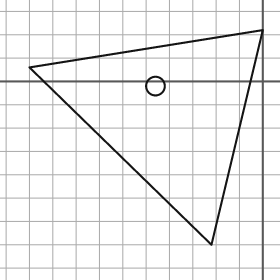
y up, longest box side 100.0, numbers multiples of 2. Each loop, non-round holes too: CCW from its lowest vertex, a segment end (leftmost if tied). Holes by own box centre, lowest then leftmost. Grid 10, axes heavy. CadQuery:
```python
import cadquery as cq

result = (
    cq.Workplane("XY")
    .moveTo(-22.0, -70.0)
    .lineTo(0.0, 22.0)
    .lineTo(-100.0, 6.0)
    .close()
    .moveTo(-46.0, -2.0)
    .circle(4.0)
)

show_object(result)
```